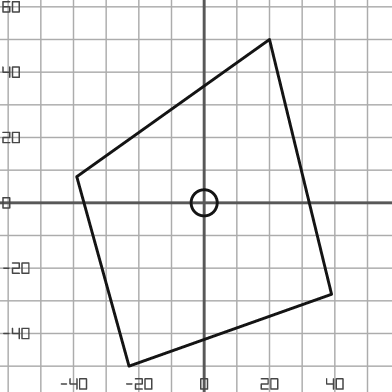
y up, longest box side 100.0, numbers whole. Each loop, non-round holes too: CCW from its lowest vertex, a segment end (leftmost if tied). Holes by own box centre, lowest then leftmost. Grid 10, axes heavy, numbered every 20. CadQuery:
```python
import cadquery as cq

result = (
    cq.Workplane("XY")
    .moveTo(-23.0, -50.0)
    .lineTo(39.0, -28.0)
    .lineTo(20.0, 50.0)
    .lineTo(-39.0, 8.0)
    .close()
    .moveTo(0.0, 0.0)
    .circle(4.0)
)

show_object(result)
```